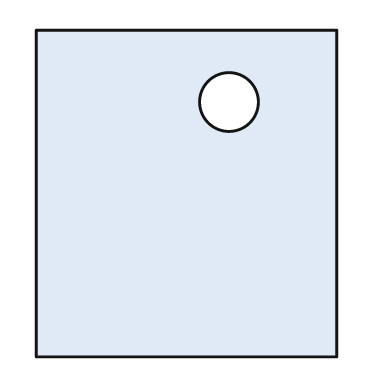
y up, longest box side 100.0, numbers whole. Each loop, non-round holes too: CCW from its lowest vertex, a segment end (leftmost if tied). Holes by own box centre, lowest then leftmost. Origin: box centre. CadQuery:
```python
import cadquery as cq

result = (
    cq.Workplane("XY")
    .moveTo(-46.0, -50.0)
    .lineTo(46.0, -50.0)
    .lineTo(46.0, 50.0)
    .lineTo(-46.0, 50.0)
    .close()
    .moveTo(13.0, 28.0)
    .circle(9.0)
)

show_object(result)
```